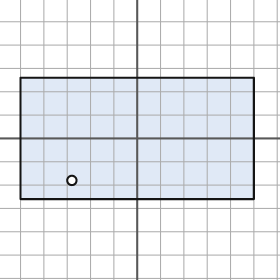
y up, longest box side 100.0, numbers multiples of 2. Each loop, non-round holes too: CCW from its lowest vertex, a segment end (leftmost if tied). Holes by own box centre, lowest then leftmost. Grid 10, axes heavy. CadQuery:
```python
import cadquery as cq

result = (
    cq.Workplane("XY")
    .moveTo(-50.0, -26.0)
    .lineTo(50.0, -26.0)
    .lineTo(50.0, 26.0)
    .lineTo(-50.0, 26.0)
    .close()
    .moveTo(-28.0, -18.0)
    .circle(2.0)
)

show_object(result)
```